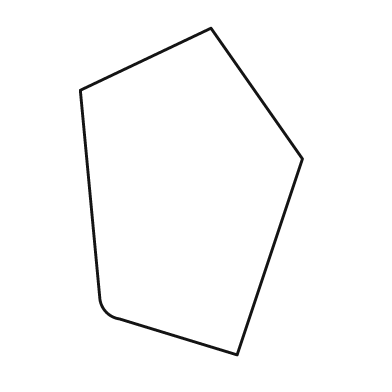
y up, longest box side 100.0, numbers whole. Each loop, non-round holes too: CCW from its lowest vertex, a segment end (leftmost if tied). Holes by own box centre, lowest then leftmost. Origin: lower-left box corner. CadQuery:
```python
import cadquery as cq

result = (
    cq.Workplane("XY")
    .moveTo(48.0, 0.0)
    .lineTo(68.0, 60.0)
    .lineTo(40.0, 100.0)
    .lineTo(0.0, 81.0)
    .lineTo(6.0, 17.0)
    .threePointArc((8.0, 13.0), (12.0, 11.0))
    .close()
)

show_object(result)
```